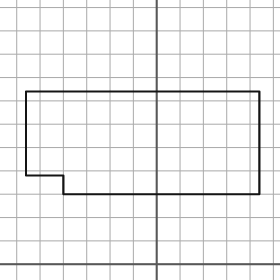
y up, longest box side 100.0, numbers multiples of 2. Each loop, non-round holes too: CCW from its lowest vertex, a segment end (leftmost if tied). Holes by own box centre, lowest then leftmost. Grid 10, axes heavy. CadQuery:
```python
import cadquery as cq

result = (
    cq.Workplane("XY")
    .moveTo(-40.0, 30.0)
    .lineTo(44.0, 30.0)
    .lineTo(44.0, 74.0)
    .lineTo(-56.0, 74.0)
    .lineTo(-56.0, 38.0)
    .lineTo(-40.0, 38.0)
    .close()
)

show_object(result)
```